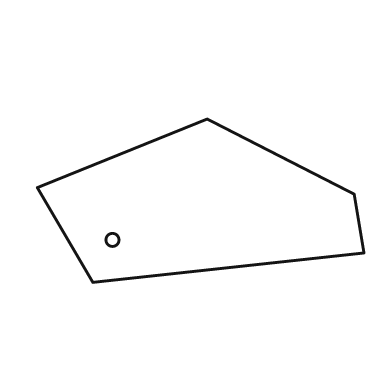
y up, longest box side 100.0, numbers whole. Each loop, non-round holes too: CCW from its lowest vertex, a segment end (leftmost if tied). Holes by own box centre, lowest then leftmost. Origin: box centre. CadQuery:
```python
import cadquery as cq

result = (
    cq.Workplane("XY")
    .moveTo(-33.0, -25.0)
    .lineTo(50.0, -16.0)
    .lineTo(47.0, 2.0)
    .lineTo(2.0, 25.0)
    .lineTo(-50.0, 4.0)
    .close()
    .moveTo(-27.0, -12.0)
    .circle(2.0)
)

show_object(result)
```